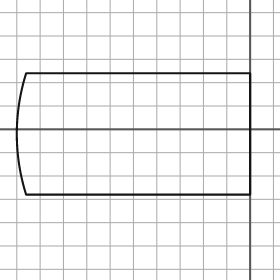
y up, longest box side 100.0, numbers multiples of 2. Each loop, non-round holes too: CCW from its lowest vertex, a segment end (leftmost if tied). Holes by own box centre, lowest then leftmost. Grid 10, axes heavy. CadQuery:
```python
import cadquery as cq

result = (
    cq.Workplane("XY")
    .moveTo(-96.0, -28.0)
    .lineTo(0.0, -28.0)
    .lineTo(0.0, 24.0)
    .lineTo(-96.0, 24.0)
    .threePointArc((-100.0, -2.0), (-96.0, -28.0))
    .close()
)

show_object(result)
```